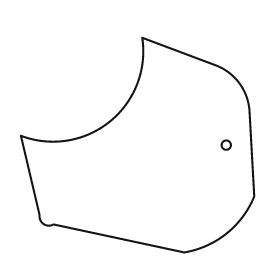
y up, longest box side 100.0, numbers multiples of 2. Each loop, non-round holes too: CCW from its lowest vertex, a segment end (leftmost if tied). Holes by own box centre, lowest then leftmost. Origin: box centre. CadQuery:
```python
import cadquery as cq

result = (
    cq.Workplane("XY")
    .moveTo(20.0, -46.0)
    .threePointArc((38.0, -38.0), (50.0, -22.0))
    .lineTo(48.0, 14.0)
    .threePointArc((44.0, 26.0), (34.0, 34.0))
    .lineTo(2.0, 46.0)
    .threePointArc((-12.0, 10.0), (-50.0, 4.0))
    .lineTo(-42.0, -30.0)
    .threePointArc((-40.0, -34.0), (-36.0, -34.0))
    .close()
    .moveTo(38.0, 0.0)
    .circle(2.0)
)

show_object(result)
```